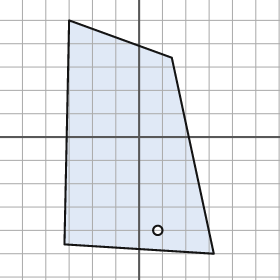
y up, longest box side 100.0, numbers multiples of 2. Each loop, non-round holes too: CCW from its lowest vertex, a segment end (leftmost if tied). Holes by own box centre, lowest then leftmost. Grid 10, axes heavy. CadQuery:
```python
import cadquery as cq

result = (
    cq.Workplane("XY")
    .moveTo(32.0, -50.0)
    .lineTo(14.0, 34.0)
    .lineTo(-30.0, 50.0)
    .lineTo(-32.0, -46.0)
    .close()
    .moveTo(8.0, -40.0)
    .circle(2.0)
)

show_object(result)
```